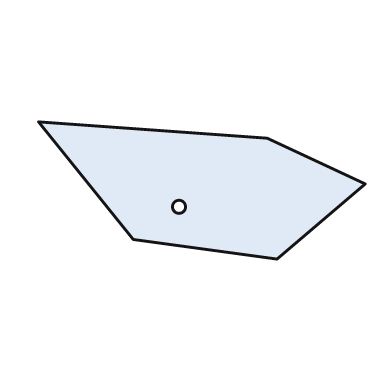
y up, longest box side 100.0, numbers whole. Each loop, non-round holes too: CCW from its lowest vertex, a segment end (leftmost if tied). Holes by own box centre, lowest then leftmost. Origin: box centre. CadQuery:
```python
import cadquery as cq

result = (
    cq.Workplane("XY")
    .moveTo(23.0, -21.0)
    .lineTo(50.0, 2.0)
    .lineTo(20.0, 16.0)
    .lineTo(-50.0, 21.0)
    .lineTo(-21.0, -15.0)
    .close()
    .moveTo(-7.0, -5.0)
    .circle(2.0)
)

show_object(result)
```